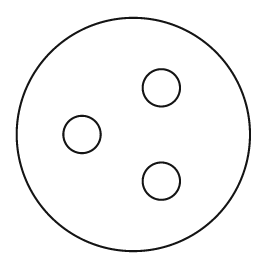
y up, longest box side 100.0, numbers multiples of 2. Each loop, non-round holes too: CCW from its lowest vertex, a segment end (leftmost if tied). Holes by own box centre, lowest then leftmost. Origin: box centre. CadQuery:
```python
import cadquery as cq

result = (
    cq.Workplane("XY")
    .moveTo(0.0, 0.0)
    .circle(50.0)
    .moveTo(12.0, -20.0)
    .circle(8.0)
    .moveTo(-22.0, 0.0)
    .circle(8.0)
    .moveTo(12.0, 20.0)
    .circle(8.0)
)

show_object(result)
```